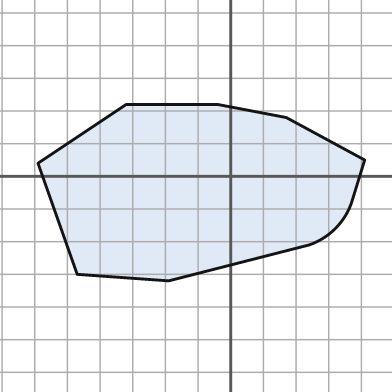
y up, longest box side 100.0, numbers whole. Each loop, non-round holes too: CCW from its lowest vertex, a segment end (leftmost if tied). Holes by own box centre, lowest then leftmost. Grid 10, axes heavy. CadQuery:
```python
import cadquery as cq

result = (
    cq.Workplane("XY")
    .moveTo(-19.0, -32.0)
    .lineTo(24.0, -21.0)
    .threePointArc((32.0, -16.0), (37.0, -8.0))
    .lineTo(41.0, 5.0)
    .lineTo(17.0, 18.0)
    .lineTo(-4.0, 22.0)
    .lineTo(-32.0, 22.0)
    .lineTo(-59.0, 4.0)
    .lineTo(-47.0, -30.0)
    .close()
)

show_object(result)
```